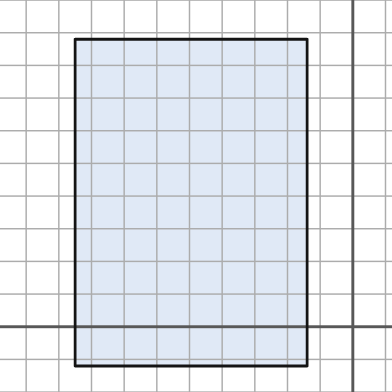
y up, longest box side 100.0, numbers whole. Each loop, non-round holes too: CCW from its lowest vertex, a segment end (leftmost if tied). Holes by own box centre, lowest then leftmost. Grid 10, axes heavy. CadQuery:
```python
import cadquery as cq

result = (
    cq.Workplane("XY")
    .moveTo(-85.0, -12.0)
    .lineTo(-14.0, -12.0)
    .lineTo(-14.0, 88.0)
    .lineTo(-85.0, 88.0)
    .close()
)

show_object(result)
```